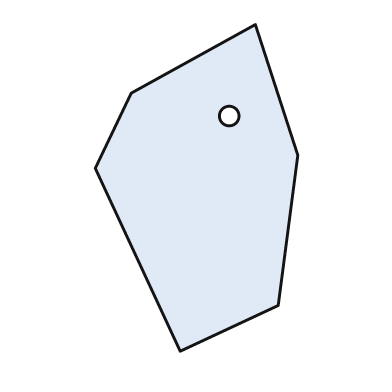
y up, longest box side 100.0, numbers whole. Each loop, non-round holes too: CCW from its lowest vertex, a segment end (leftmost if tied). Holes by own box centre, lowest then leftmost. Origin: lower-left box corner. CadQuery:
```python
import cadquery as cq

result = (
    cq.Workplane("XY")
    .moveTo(26.0, 0.0)
    .lineTo(56.0, 14.0)
    .lineTo(62.0, 60.0)
    .lineTo(49.0, 100.0)
    .lineTo(11.0, 79.0)
    .lineTo(0.0, 56.0)
    .close()
    .moveTo(41.0, 72.0)
    .circle(3.0)
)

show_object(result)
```